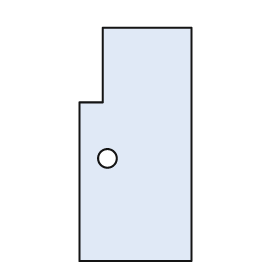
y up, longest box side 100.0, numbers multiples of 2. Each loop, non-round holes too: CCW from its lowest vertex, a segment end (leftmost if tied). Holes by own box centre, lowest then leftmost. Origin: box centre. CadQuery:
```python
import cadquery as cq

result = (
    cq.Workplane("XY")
    .moveTo(-24.0, -50.0)
    .lineTo(24.0, -50.0)
    .lineTo(24.0, 50.0)
    .lineTo(-14.0, 50.0)
    .lineTo(-14.0, 18.0)
    .lineTo(-24.0, 18.0)
    .close()
    .moveTo(-12.0, -6.0)
    .circle(4.0)
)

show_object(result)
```